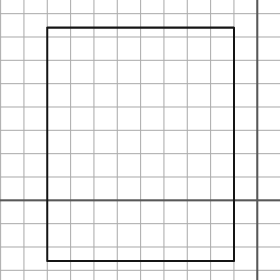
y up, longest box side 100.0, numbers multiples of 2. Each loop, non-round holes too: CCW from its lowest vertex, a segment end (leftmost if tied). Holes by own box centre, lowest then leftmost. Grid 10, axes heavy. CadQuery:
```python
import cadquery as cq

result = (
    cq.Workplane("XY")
    .moveTo(-90.0, -26.0)
    .lineTo(-10.0, -26.0)
    .lineTo(-10.0, 74.0)
    .lineTo(-90.0, 74.0)
    .close()
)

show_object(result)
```